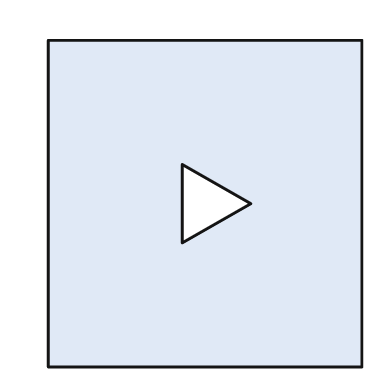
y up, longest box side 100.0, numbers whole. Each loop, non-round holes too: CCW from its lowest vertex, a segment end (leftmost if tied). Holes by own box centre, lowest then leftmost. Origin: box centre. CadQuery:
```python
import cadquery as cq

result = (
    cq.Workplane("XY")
    .moveTo(-48.0, -50.0)
    .lineTo(48.0, -50.0)
    .lineTo(48.0, 50.0)
    .lineTo(-48.0, 50.0)
    .close()
    .moveTo(-7.0, -12.0)
    .lineTo(14.0, 0.0)
    .lineTo(-7.0, 12.0)
    .close()
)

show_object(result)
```